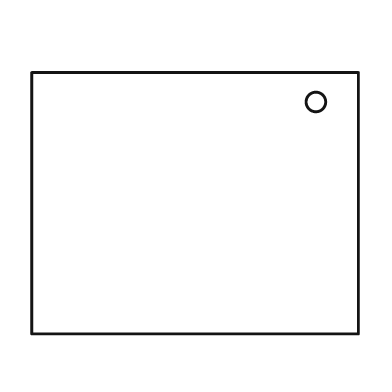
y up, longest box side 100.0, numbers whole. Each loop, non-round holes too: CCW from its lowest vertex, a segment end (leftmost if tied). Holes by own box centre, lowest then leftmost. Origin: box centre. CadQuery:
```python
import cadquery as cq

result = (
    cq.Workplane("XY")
    .moveTo(-50.0, -40.0)
    .lineTo(50.0, -40.0)
    .lineTo(50.0, 40.0)
    .lineTo(-50.0, 40.0)
    .close()
    .moveTo(37.0, 31.0)
    .circle(3.0)
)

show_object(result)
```